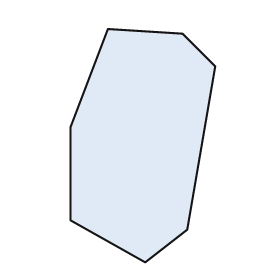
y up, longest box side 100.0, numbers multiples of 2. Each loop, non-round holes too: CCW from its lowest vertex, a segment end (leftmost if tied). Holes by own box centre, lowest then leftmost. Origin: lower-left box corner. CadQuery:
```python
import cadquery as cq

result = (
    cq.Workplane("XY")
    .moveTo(32.0, 0.0)
    .lineTo(50.0, 14.0)
    .lineTo(62.0, 84.0)
    .lineTo(48.0, 98.0)
    .lineTo(16.0, 100.0)
    .lineTo(0.0, 58.0)
    .lineTo(0.0, 18.0)
    .close()
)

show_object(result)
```